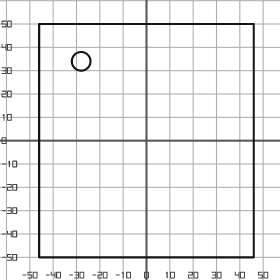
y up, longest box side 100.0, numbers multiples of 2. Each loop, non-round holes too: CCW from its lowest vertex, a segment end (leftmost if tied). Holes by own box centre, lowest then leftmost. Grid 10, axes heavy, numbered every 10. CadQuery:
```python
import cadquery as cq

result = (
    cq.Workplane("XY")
    .moveTo(-46.0, -50.0)
    .lineTo(46.0, -50.0)
    .lineTo(46.0, 50.0)
    .lineTo(-46.0, 50.0)
    .close()
    .moveTo(-28.0, 34.0)
    .circle(4.0)
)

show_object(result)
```